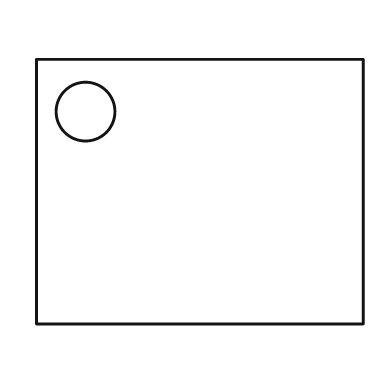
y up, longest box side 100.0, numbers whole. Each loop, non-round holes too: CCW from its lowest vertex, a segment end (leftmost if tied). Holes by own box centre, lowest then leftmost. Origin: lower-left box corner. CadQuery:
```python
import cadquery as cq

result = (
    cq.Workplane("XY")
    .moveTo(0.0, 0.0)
    .lineTo(100.0, 0.0)
    .lineTo(100.0, 81.0)
    .lineTo(0.0, 81.0)
    .close()
    .moveTo(15.0, 65.0)
    .circle(9.0)
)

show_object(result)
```